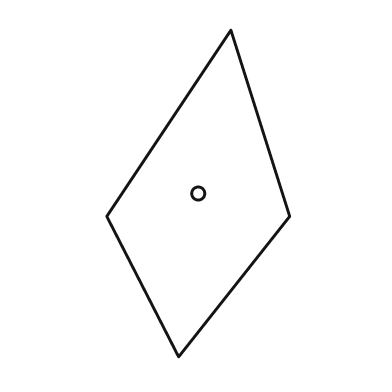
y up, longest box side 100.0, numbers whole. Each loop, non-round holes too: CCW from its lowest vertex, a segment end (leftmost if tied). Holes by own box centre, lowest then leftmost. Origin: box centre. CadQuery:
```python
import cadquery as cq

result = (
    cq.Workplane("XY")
    .moveTo(-6.0, -50.0)
    .lineTo(28.0, -7.0)
    .lineTo(10.0, 50.0)
    .lineTo(-28.0, -7.0)
    .close()
    .moveTo(0.0, 0.0)
    .circle(2.0)
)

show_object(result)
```